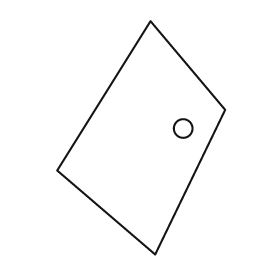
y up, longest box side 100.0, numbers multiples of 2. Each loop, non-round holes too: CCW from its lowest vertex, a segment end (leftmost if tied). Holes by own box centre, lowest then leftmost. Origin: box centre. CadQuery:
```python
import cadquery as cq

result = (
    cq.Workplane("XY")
    .moveTo(6.0, -50.0)
    .lineTo(36.0, 12.0)
    .lineTo(4.0, 50.0)
    .lineTo(-36.0, -14.0)
    .close()
    .moveTo(18.0, 4.0)
    .circle(4.0)
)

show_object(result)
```